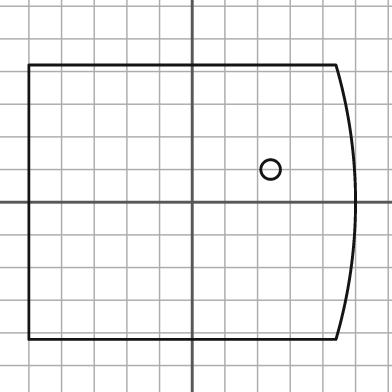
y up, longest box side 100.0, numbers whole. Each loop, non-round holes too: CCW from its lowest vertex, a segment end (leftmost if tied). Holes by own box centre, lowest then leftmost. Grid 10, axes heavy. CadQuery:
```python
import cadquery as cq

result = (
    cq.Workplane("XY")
    .moveTo(-50.0, -42.0)
    .lineTo(44.0, -42.0)
    .threePointArc((50.0, 0.0), (44.0, 42.0))
    .lineTo(-50.0, 42.0)
    .close()
    .moveTo(24.0, 10.0)
    .circle(3.0)
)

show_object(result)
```